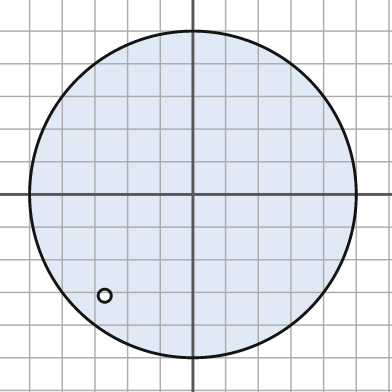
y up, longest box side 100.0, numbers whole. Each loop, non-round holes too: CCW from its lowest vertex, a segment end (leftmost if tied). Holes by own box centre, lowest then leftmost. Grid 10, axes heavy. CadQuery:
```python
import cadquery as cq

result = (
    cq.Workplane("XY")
    .moveTo(0.0, 0.0)
    .circle(50.0)
    .moveTo(-27.0, -31.0)
    .circle(2.0)
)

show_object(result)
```